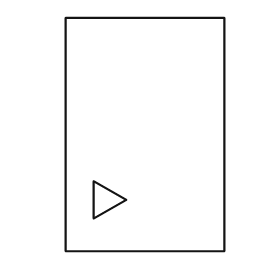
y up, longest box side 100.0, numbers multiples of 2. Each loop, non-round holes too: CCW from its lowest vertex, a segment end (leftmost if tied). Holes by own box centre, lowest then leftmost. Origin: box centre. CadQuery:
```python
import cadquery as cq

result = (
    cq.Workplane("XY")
    .moveTo(-34.0, -50.0)
    .lineTo(34.0, -50.0)
    .lineTo(34.0, 50.0)
    .lineTo(-34.0, 50.0)
    .close()
    .moveTo(-22.0, -36.0)
    .lineTo(-8.0, -28.0)
    .lineTo(-22.0, -20.0)
    .close()
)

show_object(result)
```